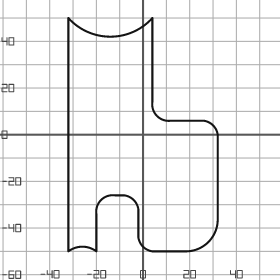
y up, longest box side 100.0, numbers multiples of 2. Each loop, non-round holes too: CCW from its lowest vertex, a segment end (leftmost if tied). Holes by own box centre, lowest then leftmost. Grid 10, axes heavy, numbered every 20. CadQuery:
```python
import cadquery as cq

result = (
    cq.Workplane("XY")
    .moveTo(-32.0, -50.0)
    .threePointArc((-26.0, -48.0), (-20.0, -50.0))
    .lineTo(-20.0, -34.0)
    .threePointArc((-18.0, -28.0), (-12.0, -26.0))
    .lineTo(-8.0, -26.0)
    .threePointArc((-4.0, -28.0), (-2.0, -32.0))
    .lineTo(-2.0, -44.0)
    .threePointArc((0.0, -48.0), (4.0, -50.0))
    .lineTo(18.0, -50.0)
    .threePointArc((28.0, -46.0), (32.0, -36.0))
    .lineTo(32.0, 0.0)
    .threePointArc((30.0, 4.0), (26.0, 6.0))
    .lineTo(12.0, 6.0)
    .threePointArc((6.0, 8.0), (4.0, 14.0))
    .lineTo(4.0, 50.0)
    .threePointArc((-14.0, 42.0), (-32.0, 50.0))
    .close()
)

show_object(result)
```